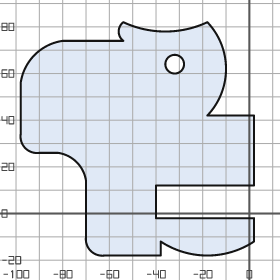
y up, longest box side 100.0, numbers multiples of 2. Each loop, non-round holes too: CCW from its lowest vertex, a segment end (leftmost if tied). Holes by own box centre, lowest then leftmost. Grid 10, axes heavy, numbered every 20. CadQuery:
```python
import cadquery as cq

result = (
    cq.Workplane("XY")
    .moveTo(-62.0, -18.0)
    .lineTo(-38.0, -18.0)
    .lineTo(-38.0, -12.0)
    .threePointArc((-18.0, -18.0), (2.0, -12.0))
    .lineTo(2.0, -2.0)
    .lineTo(-40.0, -2.0)
    .lineTo(-40.0, 12.0)
    .lineTo(2.0, 12.0)
    .lineTo(2.0, 42.0)
    .lineTo(-18.0, 42.0)
    .threePointArc((-10.0, 62.0), (-18.0, 82.0))
    .threePointArc((-36.0, 78.0), (-54.0, 82.0))
    .threePointArc((-56.0, 78.0), (-54.0, 74.0))
    .lineTo(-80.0, 74.0)
    .threePointArc((-92.0, 68.0), (-98.0, 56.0))
    .lineTo(-98.0, 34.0)
    .threePointArc((-96.0, 28.0), (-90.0, 26.0))
    .lineTo(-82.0, 26.0)
    .threePointArc((-74.0, 22.0), (-70.0, 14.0))
    .lineTo(-70.0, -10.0)
    .threePointArc((-68.0, -16.0), (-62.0, -18.0))
    .close()
    .moveTo(-32.0, 64.0)
    .circle(4.0)
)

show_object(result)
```